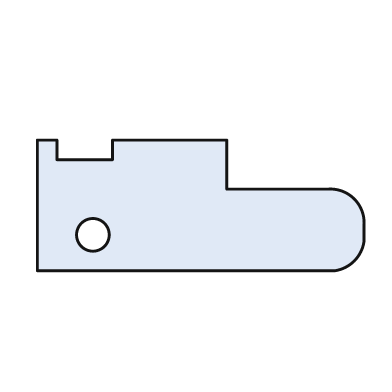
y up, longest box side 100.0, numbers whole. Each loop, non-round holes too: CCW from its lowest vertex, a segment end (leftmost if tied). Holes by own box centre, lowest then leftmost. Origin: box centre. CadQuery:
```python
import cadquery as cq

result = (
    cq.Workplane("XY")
    .moveTo(-50.0, -20.0)
    .lineTo(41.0, -20.0)
    .threePointArc((47.0, -17.0), (50.0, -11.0))
    .lineTo(50.0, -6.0)
    .threePointArc((47.0, 2.0), (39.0, 5.0))
    .lineTo(8.0, 5.0)
    .lineTo(8.0, 20.0)
    .lineTo(-27.0, 20.0)
    .lineTo(-27.0, 14.0)
    .lineTo(-44.0, 14.0)
    .lineTo(-44.0, 20.0)
    .lineTo(-50.0, 20.0)
    .close()
    .moveTo(-33.0, -9.0)
    .circle(5.0)
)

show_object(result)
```